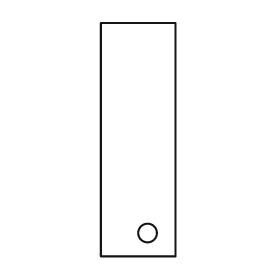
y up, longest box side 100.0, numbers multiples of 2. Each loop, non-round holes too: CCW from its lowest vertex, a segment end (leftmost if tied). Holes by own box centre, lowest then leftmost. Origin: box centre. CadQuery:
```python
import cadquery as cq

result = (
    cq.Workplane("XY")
    .moveTo(-16.0, -50.0)
    .lineTo(16.0, -50.0)
    .lineTo(16.0, 50.0)
    .lineTo(-16.0, 50.0)
    .close()
    .moveTo(4.0, -40.0)
    .circle(4.0)
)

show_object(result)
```